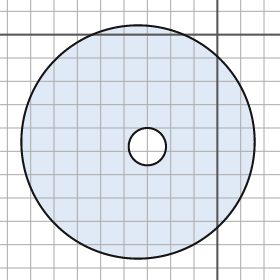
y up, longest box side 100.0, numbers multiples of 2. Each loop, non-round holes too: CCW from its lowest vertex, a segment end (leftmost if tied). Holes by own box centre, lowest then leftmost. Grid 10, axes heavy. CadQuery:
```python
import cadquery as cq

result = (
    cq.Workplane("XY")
    .moveTo(-34.0, -46.0)
    .circle(50.0)
    .moveTo(-30.0, -48.0)
    .circle(8.0)
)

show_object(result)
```